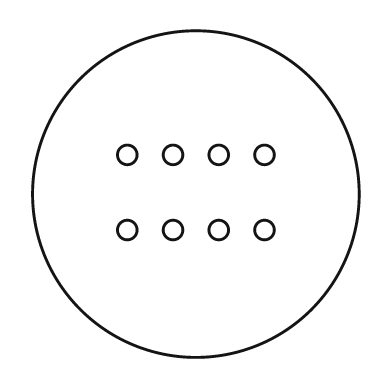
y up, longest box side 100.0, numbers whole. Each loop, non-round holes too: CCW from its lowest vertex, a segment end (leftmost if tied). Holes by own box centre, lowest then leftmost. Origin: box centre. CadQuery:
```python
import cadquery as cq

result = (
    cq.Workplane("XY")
    .moveTo(0.0, 0.0)
    .circle(50.0)
    .moveTo(-21.0, -11.0)
    .circle(3.0)
    .moveTo(-7.0, -11.0)
    .circle(3.0)
    .moveTo(7.0, -11.0)
    .circle(3.0)
    .moveTo(21.0, -11.0)
    .circle(3.0)
    .moveTo(-21.0, 12.0)
    .circle(3.0)
    .moveTo(-7.0, 12.0)
    .circle(3.0)
    .moveTo(7.0, 12.0)
    .circle(3.0)
    .moveTo(21.0, 12.0)
    .circle(3.0)
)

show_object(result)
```